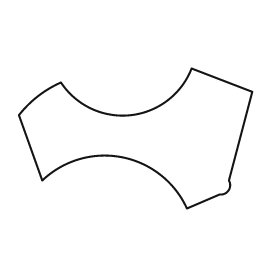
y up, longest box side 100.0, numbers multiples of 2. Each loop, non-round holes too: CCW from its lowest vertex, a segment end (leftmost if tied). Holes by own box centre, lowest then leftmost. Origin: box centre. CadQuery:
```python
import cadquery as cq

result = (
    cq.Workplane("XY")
    .moveTo(22.0, -30.0)
    .lineTo(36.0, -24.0)
    .threePointArc((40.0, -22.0), (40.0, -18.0))
    .lineTo(50.0, 20.0)
    .lineTo(24.0, 30.0)
    .threePointArc((-2.0, 10.0), (-32.0, 24.0))
    .threePointArc((-42.0, 18.0), (-50.0, 10.0))
    .lineTo(-40.0, -18.0)
    .threePointArc((-6.0, -8.0), (22.0, -30.0))
    .close()
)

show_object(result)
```